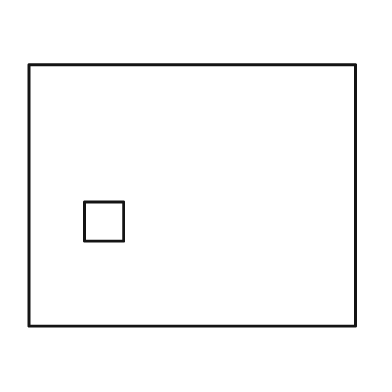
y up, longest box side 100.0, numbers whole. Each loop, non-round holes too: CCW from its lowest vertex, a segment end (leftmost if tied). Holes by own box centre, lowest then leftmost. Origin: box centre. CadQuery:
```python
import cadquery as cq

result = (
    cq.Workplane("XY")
    .moveTo(-50.0, -40.0)
    .lineTo(50.0, -40.0)
    .lineTo(50.0, 40.0)
    .lineTo(-50.0, 40.0)
    .close()
    .moveTo(-33.0, -14.0)
    .lineTo(-21.0, -14.0)
    .lineTo(-21.0, -2.0)
    .lineTo(-33.0, -2.0)
    .close()
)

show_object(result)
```